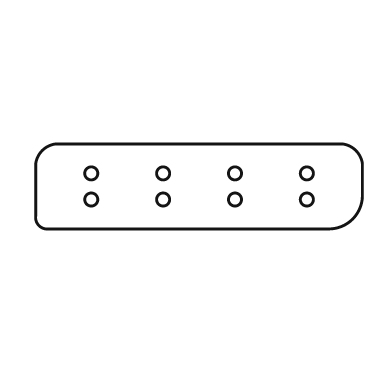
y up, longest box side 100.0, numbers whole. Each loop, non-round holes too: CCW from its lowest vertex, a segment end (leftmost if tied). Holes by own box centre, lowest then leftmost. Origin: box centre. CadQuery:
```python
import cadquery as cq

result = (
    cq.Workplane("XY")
    .moveTo(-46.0, -13.0)
    .lineTo(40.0, -13.0)
    .threePointArc((47.0, -10.0), (50.0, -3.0))
    .lineTo(50.0, 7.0)
    .threePointArc((48.0, 11.0), (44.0, 13.0))
    .lineTo(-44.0, 13.0)
    .threePointArc((-48.0, 11.0), (-50.0, 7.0))
    .lineTo(-50.0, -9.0)
    .threePointArc((-49.0, -12.0), (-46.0, -13.0))
    .close()
    .moveTo(-33.0, -4.0)
    .circle(2.0)
    .moveTo(-11.0, -4.0)
    .circle(2.0)
    .moveTo(11.0, -4.0)
    .circle(2.0)
    .moveTo(33.0, -4.0)
    .circle(2.0)
    .moveTo(-33.0, 4.0)
    .circle(2.0)
    .moveTo(-11.0, 4.0)
    .circle(2.0)
    .moveTo(11.0, 4.0)
    .circle(2.0)
    .moveTo(33.0, 4.0)
    .circle(2.0)
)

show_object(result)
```